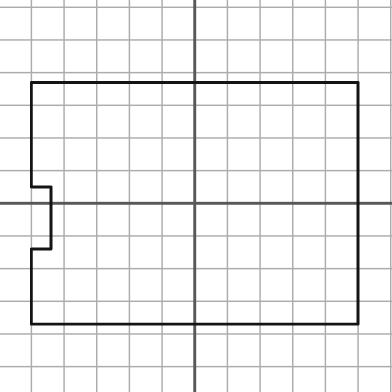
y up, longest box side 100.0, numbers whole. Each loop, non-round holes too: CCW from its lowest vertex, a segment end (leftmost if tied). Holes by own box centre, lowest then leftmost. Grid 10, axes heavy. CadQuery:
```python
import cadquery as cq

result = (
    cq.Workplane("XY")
    .moveTo(-50.0, -37.0)
    .lineTo(50.0, -37.0)
    .lineTo(50.0, 37.0)
    .lineTo(-50.0, 37.0)
    .lineTo(-50.0, 5.0)
    .lineTo(-44.0, 5.0)
    .lineTo(-44.0, -14.0)
    .lineTo(-50.0, -14.0)
    .close()
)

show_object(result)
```